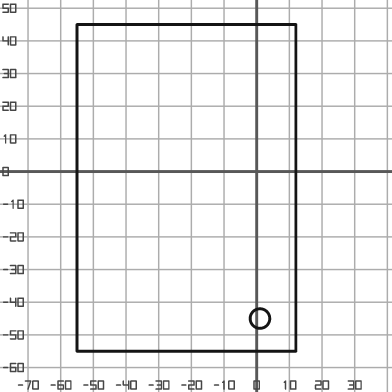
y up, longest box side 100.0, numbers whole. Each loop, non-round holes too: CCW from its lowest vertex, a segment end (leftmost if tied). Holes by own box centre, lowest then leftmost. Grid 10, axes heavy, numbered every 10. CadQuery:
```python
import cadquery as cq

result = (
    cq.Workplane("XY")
    .moveTo(-55.0, -55.0)
    .lineTo(12.0, -55.0)
    .lineTo(12.0, 45.0)
    .lineTo(-55.0, 45.0)
    .close()
    .moveTo(1.0, -45.0)
    .circle(3.0)
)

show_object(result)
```